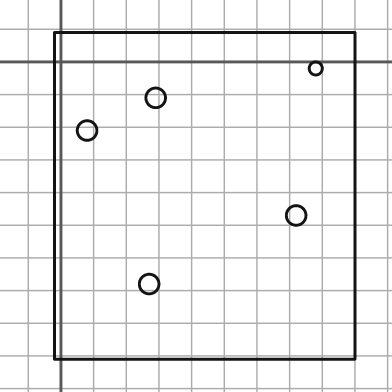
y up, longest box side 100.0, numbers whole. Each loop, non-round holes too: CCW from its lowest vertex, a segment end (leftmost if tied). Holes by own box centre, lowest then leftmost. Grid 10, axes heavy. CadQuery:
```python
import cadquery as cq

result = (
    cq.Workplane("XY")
    .moveTo(-2.0, -91.0)
    .lineTo(90.0, -91.0)
    .lineTo(90.0, 9.0)
    .lineTo(-2.0, 9.0)
    .close()
    .moveTo(27.0, -68.0)
    .circle(3.0)
    .moveTo(72.0, -47.0)
    .circle(3.0)
    .moveTo(8.0, -21.0)
    .circle(3.0)
    .moveTo(29.0, -11.0)
    .circle(3.0)
    .moveTo(78.0, -2.0)
    .circle(2.0)
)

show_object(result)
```